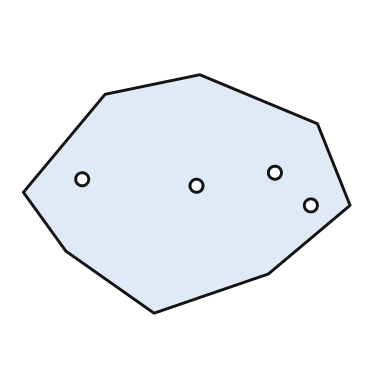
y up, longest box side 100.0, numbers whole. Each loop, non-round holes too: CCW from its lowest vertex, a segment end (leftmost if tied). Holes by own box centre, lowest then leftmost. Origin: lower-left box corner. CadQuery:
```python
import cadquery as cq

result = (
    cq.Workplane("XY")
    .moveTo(40.0, 0.0)
    .lineTo(75.0, 12.0)
    .lineTo(100.0, 33.0)
    .lineTo(90.0, 58.0)
    .lineTo(54.0, 73.0)
    .lineTo(25.0, 67.0)
    .lineTo(0.0, 37.0)
    .lineTo(13.0, 19.0)
    .close()
    .moveTo(88.0, 33.0)
    .circle(2.0)
    .moveTo(53.0, 39.0)
    .circle(2.0)
    .moveTo(18.0, 41.0)
    .circle(2.0)
    .moveTo(77.0, 43.0)
    .circle(2.0)
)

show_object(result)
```